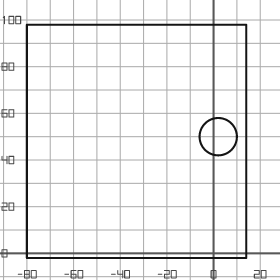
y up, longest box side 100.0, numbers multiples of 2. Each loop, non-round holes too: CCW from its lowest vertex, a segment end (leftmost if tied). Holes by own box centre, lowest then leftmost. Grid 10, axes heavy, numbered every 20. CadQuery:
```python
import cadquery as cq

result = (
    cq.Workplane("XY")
    .moveTo(-80.0, -2.0)
    .lineTo(14.0, -2.0)
    .lineTo(14.0, 98.0)
    .lineTo(-80.0, 98.0)
    .close()
    .moveTo(2.0, 50.0)
    .circle(8.0)
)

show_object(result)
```